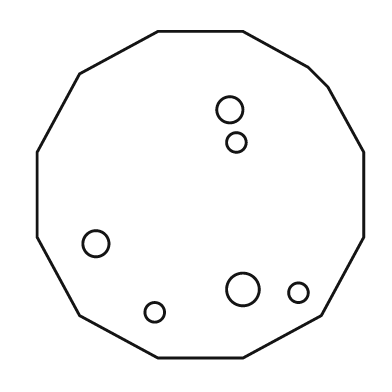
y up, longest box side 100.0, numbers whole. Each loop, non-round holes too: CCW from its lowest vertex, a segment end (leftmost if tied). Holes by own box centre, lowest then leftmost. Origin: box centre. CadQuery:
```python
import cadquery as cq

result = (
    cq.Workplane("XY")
    .moveTo(-13.0, -50.0)
    .lineTo(13.0, -50.0)
    .lineTo(37.0, -37.0)
    .lineTo(50.0, -13.0)
    .lineTo(50.0, 13.0)
    .lineTo(39.0, 33.0)
    .lineTo(33.0, 39.0)
    .lineTo(13.0, 50.0)
    .lineTo(-13.0, 50.0)
    .lineTo(-37.0, 37.0)
    .lineTo(-50.0, 13.0)
    .lineTo(-50.0, -13.0)
    .lineTo(-37.0, -37.0)
    .close()
    .moveTo(-14.0, -36.0)
    .circle(3.0)
    .moveTo(30.0, -30.0)
    .circle(3.0)
    .moveTo(13.0, -29.0)
    .circle(5.0)
    .moveTo(-32.0, -15.0)
    .circle(4.0)
    .moveTo(11.0, 16.0)
    .circle(3.0)
    .moveTo(9.0, 26.0)
    .circle(4.0)
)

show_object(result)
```